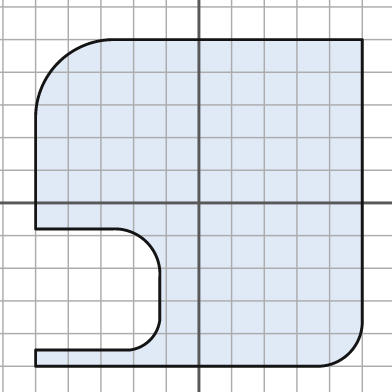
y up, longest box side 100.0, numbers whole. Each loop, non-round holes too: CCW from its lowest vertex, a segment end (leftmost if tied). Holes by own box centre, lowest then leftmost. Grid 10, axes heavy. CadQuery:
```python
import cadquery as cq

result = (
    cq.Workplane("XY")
    .moveTo(-50.0, -50.0)
    .lineTo(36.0, -50.0)
    .threePointArc((46.0, -46.0), (50.0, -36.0))
    .lineTo(50.0, 50.0)
    .lineTo(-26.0, 50.0)
    .threePointArc((-43.0, 43.0), (-50.0, 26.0))
    .lineTo(-50.0, -8.0)
    .lineTo(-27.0, -8.0)
    .threePointArc((-16.0, -12.0), (-12.0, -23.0))
    .lineTo(-12.0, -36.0)
    .threePointArc((-15.0, -42.0), (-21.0, -45.0))
    .lineTo(-50.0, -45.0)
    .close()
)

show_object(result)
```